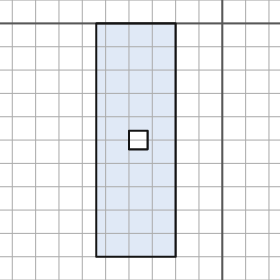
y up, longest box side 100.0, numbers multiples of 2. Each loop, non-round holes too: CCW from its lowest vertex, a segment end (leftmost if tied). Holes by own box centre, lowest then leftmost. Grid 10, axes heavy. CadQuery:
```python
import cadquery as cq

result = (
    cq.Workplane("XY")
    .moveTo(-54.0, -100.0)
    .lineTo(-20.0, -100.0)
    .lineTo(-20.0, 0.0)
    .lineTo(-54.0, 0.0)
    .close()
    .moveTo(-40.0, -54.0)
    .lineTo(-32.0, -54.0)
    .lineTo(-32.0, -46.0)
    .lineTo(-40.0, -46.0)
    .close()
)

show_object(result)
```